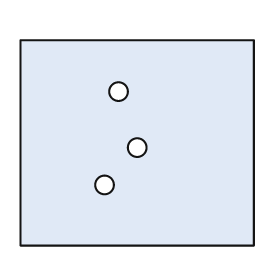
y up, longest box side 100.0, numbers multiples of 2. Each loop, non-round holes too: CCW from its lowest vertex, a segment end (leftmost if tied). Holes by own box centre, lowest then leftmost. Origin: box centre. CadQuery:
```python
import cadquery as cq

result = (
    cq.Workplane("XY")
    .moveTo(-50.0, -44.0)
    .lineTo(50.0, -44.0)
    .lineTo(50.0, 44.0)
    .lineTo(-50.0, 44.0)
    .close()
    .moveTo(-14.0, -18.0)
    .circle(4.0)
    .moveTo(0.0, -2.0)
    .circle(4.0)
    .moveTo(-8.0, 22.0)
    .circle(4.0)
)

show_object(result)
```